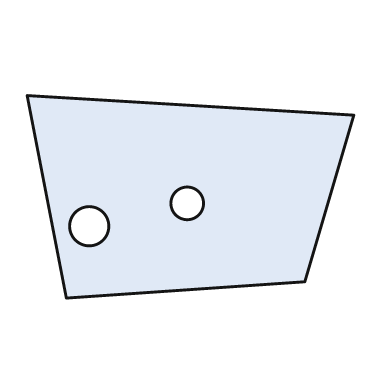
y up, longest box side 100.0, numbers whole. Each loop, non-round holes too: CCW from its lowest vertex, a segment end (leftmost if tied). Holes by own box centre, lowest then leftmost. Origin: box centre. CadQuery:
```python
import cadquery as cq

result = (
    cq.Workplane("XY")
    .moveTo(-38.0, -31.0)
    .lineTo(35.0, -26.0)
    .lineTo(50.0, 25.0)
    .lineTo(-50.0, 31.0)
    .close()
    .moveTo(-31.0, -9.0)
    .circle(6.0)
    .moveTo(-1.0, -2.0)
    .circle(5.0)
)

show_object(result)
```